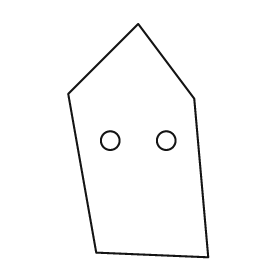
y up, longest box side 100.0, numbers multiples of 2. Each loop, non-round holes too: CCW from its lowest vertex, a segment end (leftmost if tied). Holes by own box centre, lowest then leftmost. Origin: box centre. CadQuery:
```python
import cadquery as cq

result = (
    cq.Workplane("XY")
    .moveTo(30.0, -50.0)
    .lineTo(24.0, 18.0)
    .lineTo(0.0, 50.0)
    .lineTo(-30.0, 20.0)
    .lineTo(-18.0, -48.0)
    .close()
    .moveTo(-12.0, 0.0)
    .circle(4.0)
    .moveTo(12.0, 0.0)
    .circle(4.0)
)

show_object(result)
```